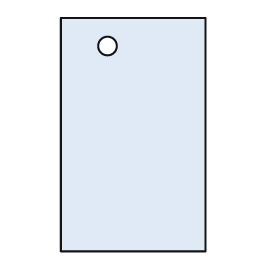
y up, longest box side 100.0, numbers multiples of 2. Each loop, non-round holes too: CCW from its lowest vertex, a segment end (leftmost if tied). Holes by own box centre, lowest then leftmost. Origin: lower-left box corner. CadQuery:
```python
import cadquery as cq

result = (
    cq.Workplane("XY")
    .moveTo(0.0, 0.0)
    .lineTo(62.0, 0.0)
    .lineTo(62.0, 100.0)
    .lineTo(0.0, 100.0)
    .close()
    .moveTo(20.0, 88.0)
    .circle(4.0)
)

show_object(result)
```